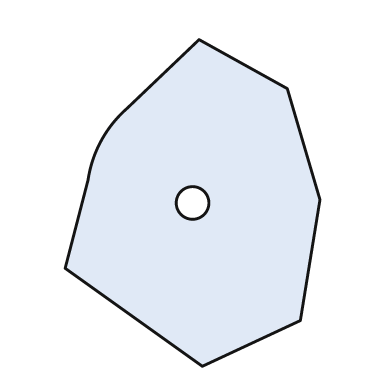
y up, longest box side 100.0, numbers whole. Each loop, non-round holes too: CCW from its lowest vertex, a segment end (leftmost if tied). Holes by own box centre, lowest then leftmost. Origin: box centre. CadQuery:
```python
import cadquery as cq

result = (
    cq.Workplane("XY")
    .moveTo(3.0, -50.0)
    .lineTo(33.0, -36.0)
    .lineTo(39.0, 1.0)
    .lineTo(29.0, 35.0)
    .lineTo(2.0, 50.0)
    .lineTo(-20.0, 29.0)
    .threePointArc((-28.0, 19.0), (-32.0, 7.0))
    .lineTo(-39.0, -20.0)
    .close()
    .moveTo(0.0, 0.0)
    .circle(5.0)
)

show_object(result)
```